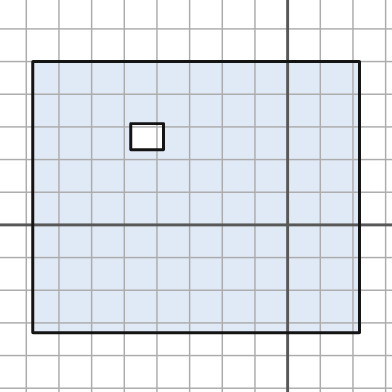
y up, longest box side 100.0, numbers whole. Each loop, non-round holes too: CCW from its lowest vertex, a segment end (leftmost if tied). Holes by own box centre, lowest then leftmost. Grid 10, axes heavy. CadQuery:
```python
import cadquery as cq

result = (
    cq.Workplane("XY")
    .moveTo(-78.0, -33.0)
    .lineTo(22.0, -33.0)
    .lineTo(22.0, 50.0)
    .lineTo(-78.0, 50.0)
    .close()
    .moveTo(-48.0, 23.0)
    .lineTo(-38.0, 23.0)
    .lineTo(-38.0, 31.0)
    .lineTo(-48.0, 31.0)
    .close()
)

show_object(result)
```